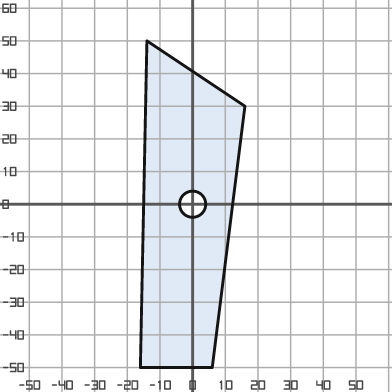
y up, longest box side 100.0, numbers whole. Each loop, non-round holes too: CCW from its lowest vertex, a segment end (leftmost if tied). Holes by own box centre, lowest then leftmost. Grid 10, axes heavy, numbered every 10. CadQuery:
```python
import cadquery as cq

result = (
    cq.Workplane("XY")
    .moveTo(-16.0, -50.0)
    .lineTo(6.0, -50.0)
    .lineTo(16.0, 30.0)
    .lineTo(-14.0, 50.0)
    .close()
    .moveTo(0.0, 0.0)
    .circle(4.0)
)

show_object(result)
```